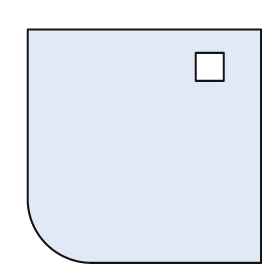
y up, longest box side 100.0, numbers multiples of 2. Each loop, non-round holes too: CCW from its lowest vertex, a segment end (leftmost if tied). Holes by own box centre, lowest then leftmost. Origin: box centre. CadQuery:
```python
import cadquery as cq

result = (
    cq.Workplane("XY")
    .moveTo(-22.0, -50.0)
    .lineTo(50.0, -50.0)
    .lineTo(50.0, 50.0)
    .lineTo(-50.0, 50.0)
    .lineTo(-50.0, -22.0)
    .threePointArc((-42.0, -42.0), (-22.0, -50.0))
    .close()
    .moveTo(22.0, 28.0)
    .lineTo(34.0, 28.0)
    .lineTo(34.0, 40.0)
    .lineTo(22.0, 40.0)
    .close()
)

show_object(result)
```